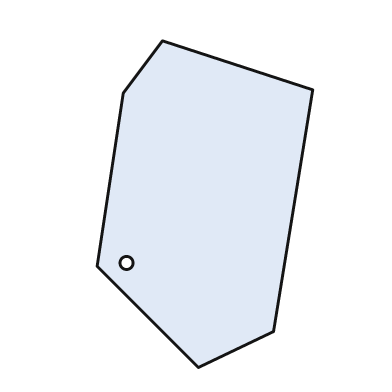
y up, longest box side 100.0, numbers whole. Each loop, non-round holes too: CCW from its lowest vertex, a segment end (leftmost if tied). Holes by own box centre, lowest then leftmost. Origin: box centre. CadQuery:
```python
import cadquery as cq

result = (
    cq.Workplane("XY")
    .moveTo(-2.0, -50.0)
    .lineTo(21.0, -39.0)
    .lineTo(33.0, 35.0)
    .lineTo(-13.0, 50.0)
    .lineTo(-25.0, 34.0)
    .lineTo(-33.0, -19.0)
    .close()
    .moveTo(-24.0, -18.0)
    .circle(2.0)
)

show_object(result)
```